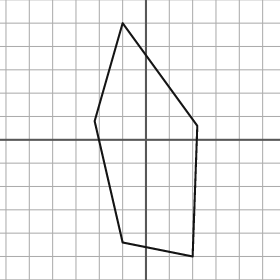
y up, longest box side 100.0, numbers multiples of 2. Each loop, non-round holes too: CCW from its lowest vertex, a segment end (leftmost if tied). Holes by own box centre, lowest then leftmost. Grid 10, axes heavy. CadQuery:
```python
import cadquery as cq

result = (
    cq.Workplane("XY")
    .moveTo(20.0, -50.0)
    .lineTo(22.0, 6.0)
    .lineTo(-10.0, 50.0)
    .lineTo(-22.0, 8.0)
    .lineTo(-10.0, -44.0)
    .close()
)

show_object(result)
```